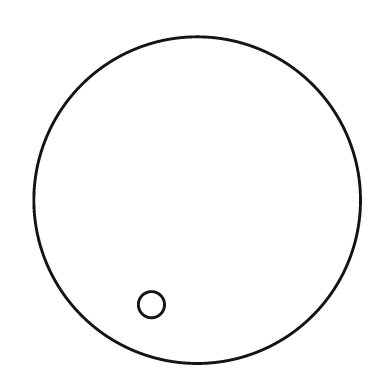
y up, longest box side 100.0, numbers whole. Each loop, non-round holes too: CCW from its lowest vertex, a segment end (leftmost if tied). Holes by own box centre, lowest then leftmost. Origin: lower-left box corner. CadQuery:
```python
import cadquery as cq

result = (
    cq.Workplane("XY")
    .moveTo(50.0, 50.0)
    .circle(50.0)
    .moveTo(36.0, 18.0)
    .circle(4.0)
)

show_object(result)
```